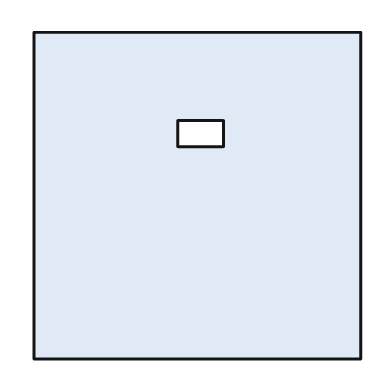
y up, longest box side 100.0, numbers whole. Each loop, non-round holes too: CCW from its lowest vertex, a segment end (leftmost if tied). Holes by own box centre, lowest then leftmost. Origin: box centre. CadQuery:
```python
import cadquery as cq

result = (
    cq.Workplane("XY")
    .moveTo(-50.0, -50.0)
    .lineTo(50.0, -50.0)
    .lineTo(50.0, 50.0)
    .lineTo(-50.0, 50.0)
    .close()
    .moveTo(-6.0, 15.0)
    .lineTo(8.0, 15.0)
    .lineTo(8.0, 23.0)
    .lineTo(-6.0, 23.0)
    .close()
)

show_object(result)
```